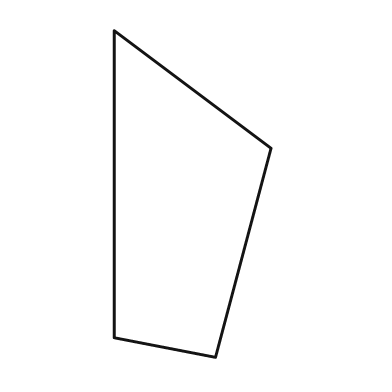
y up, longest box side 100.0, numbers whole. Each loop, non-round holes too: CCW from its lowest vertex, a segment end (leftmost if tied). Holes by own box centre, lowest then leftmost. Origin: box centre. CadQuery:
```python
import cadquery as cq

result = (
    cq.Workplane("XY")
    .moveTo(7.0, -50.0)
    .lineTo(24.0, 14.0)
    .lineTo(-24.0, 50.0)
    .lineTo(-24.0, -44.0)
    .close()
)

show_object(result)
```